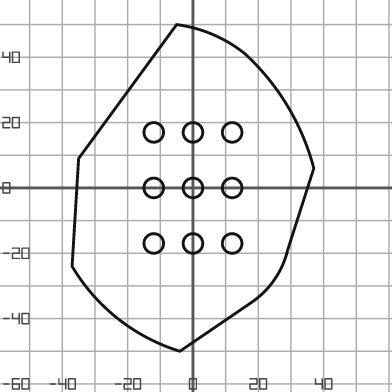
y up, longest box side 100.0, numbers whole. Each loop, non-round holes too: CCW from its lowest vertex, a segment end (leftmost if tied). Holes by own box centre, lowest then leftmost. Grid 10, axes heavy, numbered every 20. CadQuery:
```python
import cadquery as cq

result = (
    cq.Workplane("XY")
    .moveTo(-4.0, -50.0)
    .lineTo(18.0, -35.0)
    .threePointArc((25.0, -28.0), (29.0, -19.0))
    .lineTo(37.0, 6.0)
    .threePointArc((29.0, 25.0), (16.0, 41.0))
    .threePointArc((6.0, 47.0), (-5.0, 50.0))
    .lineTo(-35.0, 9.0)
    .lineTo(-37.0, -24.0)
    .threePointArc((-23.0, -40.0), (-4.0, -50.0))
    .close()
    .moveTo(-12.0, -17.0)
    .circle(3.0)
    .moveTo(0.0, -17.0)
    .circle(3.0)
    .moveTo(12.0, -17.0)
    .circle(3.0)
    .moveTo(-12.0, 0.0)
    .circle(3.0)
    .moveTo(0.0, 0.0)
    .circle(3.0)
    .moveTo(12.0, 0.0)
    .circle(3.0)
    .moveTo(-12.0, 17.0)
    .circle(3.0)
    .moveTo(0.0, 17.0)
    .circle(3.0)
    .moveTo(12.0, 17.0)
    .circle(3.0)
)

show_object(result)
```